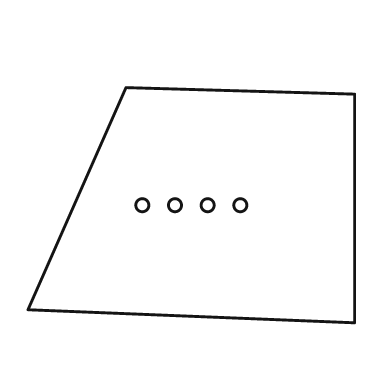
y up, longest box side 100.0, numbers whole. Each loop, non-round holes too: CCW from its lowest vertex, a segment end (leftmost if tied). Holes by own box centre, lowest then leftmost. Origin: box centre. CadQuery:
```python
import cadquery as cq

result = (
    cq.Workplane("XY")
    .moveTo(50.0, -36.0)
    .lineTo(50.0, 34.0)
    .lineTo(-20.0, 36.0)
    .lineTo(-50.0, -32.0)
    .close()
    .moveTo(-15.0, 0.0)
    .circle(2.0)
    .moveTo(-5.0, 0.0)
    .circle(2.0)
    .moveTo(5.0, 0.0)
    .circle(2.0)
    .moveTo(15.0, 0.0)
    .circle(2.0)
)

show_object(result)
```